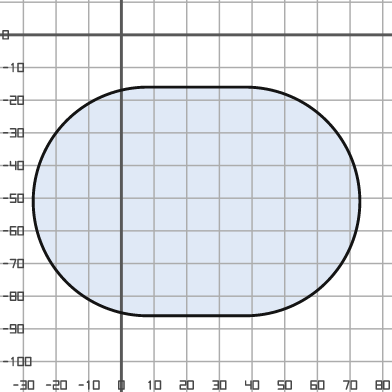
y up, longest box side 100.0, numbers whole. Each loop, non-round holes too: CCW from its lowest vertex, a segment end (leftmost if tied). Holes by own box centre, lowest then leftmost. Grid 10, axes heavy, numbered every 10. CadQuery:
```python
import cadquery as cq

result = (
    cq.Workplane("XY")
    .moveTo(8.0, -86.0)
    .lineTo(38.0, -86.0)
    .threePointArc((73.0, -51.0), (38.0, -16.0))
    .lineTo(8.0, -16.0)
    .threePointArc((-27.0, -51.0), (8.0, -86.0))
    .close()
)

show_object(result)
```